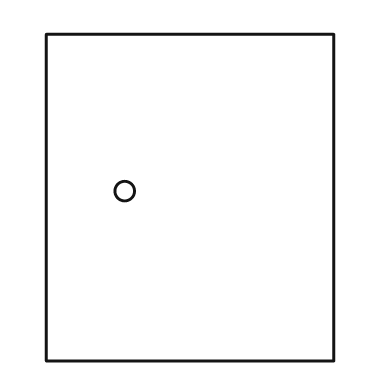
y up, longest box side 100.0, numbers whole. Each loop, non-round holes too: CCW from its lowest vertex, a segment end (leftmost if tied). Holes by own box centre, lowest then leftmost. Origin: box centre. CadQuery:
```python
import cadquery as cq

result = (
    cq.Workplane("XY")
    .moveTo(-44.0, -50.0)
    .lineTo(44.0, -50.0)
    .lineTo(44.0, 50.0)
    .lineTo(-44.0, 50.0)
    .close()
    .moveTo(-20.0, 2.0)
    .circle(3.0)
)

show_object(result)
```